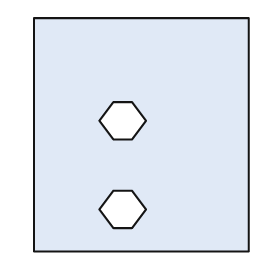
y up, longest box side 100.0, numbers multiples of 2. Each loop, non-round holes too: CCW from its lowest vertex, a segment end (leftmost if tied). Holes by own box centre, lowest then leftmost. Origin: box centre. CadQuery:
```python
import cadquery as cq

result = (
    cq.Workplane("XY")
    .moveTo(-46.0, -50.0)
    .lineTo(46.0, -50.0)
    .lineTo(46.0, 50.0)
    .lineTo(-46.0, 50.0)
    .close()
    .moveTo(-12.0, -40.0)
    .lineTo(-4.0, -40.0)
    .lineTo(2.0, -32.0)
    .lineTo(-4.0, -24.0)
    .lineTo(-12.0, -24.0)
    .lineTo(-18.0, -32.0)
    .close()
    .moveTo(-12.0, -2.0)
    .lineTo(-4.0, -2.0)
    .lineTo(2.0, 6.0)
    .lineTo(-4.0, 14.0)
    .lineTo(-12.0, 14.0)
    .lineTo(-18.0, 6.0)
    .close()
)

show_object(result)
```